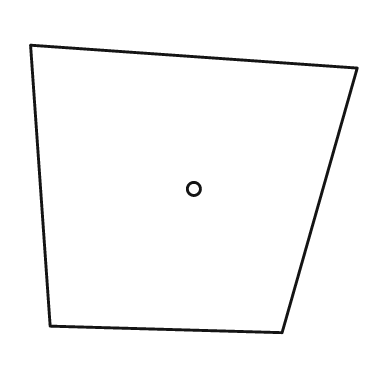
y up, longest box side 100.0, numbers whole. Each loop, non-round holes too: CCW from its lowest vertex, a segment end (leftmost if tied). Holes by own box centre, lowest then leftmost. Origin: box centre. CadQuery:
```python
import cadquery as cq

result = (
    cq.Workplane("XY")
    .moveTo(27.0, -44.0)
    .lineTo(50.0, 37.0)
    .lineTo(-50.0, 44.0)
    .lineTo(-44.0, -42.0)
    .close()
    .moveTo(0.0, 0.0)
    .circle(2.0)
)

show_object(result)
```